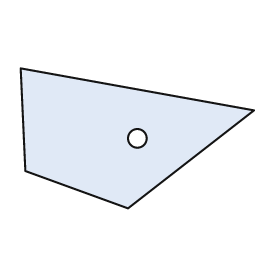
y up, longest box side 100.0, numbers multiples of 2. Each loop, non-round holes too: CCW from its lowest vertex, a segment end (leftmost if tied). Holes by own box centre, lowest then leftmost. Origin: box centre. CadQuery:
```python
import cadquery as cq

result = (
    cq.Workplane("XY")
    .moveTo(-4.0, -30.0)
    .lineTo(50.0, 12.0)
    .lineTo(-50.0, 30.0)
    .lineTo(-48.0, -14.0)
    .close()
    .moveTo(0.0, 0.0)
    .circle(4.0)
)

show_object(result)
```